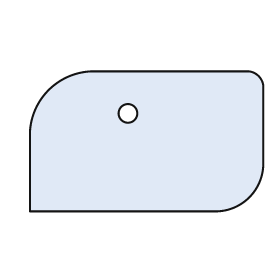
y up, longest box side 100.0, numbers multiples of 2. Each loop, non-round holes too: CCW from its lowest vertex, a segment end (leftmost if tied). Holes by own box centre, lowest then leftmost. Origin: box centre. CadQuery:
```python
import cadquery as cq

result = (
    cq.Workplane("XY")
    .moveTo(-50.0, -30.0)
    .lineTo(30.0, -30.0)
    .threePointArc((44.0, -24.0), (50.0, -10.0))
    .lineTo(50.0, 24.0)
    .threePointArc((48.0, 28.0), (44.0, 30.0))
    .lineTo(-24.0, 30.0)
    .threePointArc((-42.0, 22.0), (-50.0, 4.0))
    .close()
    .moveTo(-8.0, 12.0)
    .circle(4.0)
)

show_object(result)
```